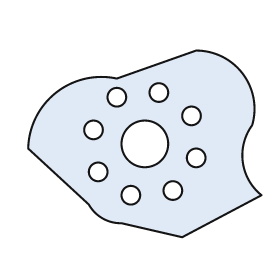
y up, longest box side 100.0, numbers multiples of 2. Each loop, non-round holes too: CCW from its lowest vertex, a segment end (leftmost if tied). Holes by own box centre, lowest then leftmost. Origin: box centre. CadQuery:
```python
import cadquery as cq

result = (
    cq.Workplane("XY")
    .moveTo(16.0, -40.0)
    .lineTo(50.0, -22.0)
    .threePointArc((42.0, -8.0), (46.0, 8.0))
    .threePointArc((42.0, 30.0), (22.0, 40.0))
    .lineTo(-12.0, 28.0)
    .threePointArc((-38.0, 22.0), (-50.0, -2.0))
    .lineTo(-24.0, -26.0)
    .threePointArc((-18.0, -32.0), (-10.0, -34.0))
    .close()
    .moveTo(-6.0, -22.0)
    .circle(4.0)
    .moveTo(12.0, -20.0)
    .circle(4.0)
    .moveTo(-20.0, -12.0)
    .circle(4.0)
    .moveTo(22.0, -6.0)
    .circle(4.0)
    .moveTo(0.0, 0.0)
    .circle(10.0)
    .moveTo(-22.0, 6.0)
    .circle(4.0)
    .moveTo(20.0, 12.0)
    .circle(4.0)
    .moveTo(-12.0, 20.0)
    .circle(4.0)
    .moveTo(6.0, 22.0)
    .circle(4.0)
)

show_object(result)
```